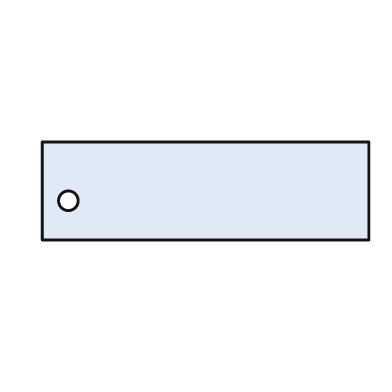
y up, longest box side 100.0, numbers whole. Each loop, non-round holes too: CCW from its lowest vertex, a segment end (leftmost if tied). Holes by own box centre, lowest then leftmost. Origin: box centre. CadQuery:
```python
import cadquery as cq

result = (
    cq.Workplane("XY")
    .moveTo(-50.0, -15.0)
    .lineTo(50.0, -15.0)
    .lineTo(50.0, 15.0)
    .lineTo(-50.0, 15.0)
    .close()
    .moveTo(-42.0, -3.0)
    .circle(3.0)
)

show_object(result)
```